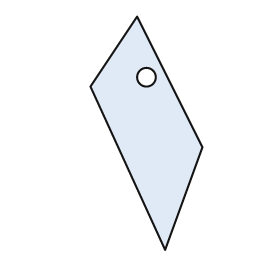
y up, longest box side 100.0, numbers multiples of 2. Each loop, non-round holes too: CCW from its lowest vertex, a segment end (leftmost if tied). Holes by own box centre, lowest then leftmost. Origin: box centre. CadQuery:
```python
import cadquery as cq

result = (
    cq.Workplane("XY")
    .moveTo(8.0, -50.0)
    .lineTo(24.0, -6.0)
    .lineTo(-4.0, 50.0)
    .lineTo(-24.0, 20.0)
    .close()
    .moveTo(0.0, 24.0)
    .circle(4.0)
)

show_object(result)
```